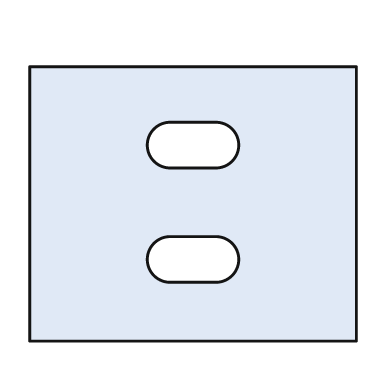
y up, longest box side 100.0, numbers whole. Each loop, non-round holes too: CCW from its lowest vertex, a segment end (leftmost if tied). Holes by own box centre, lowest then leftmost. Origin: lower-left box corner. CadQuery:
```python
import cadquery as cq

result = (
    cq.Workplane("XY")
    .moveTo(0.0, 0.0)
    .lineTo(100.0, 0.0)
    .lineTo(100.0, 84.0)
    .lineTo(0.0, 84.0)
    .close()
    .moveTo(43.0, 18.0)
    .lineTo(57.0, 18.0)
    .threePointArc((64.0, 25.0), (57.0, 32.0))
    .lineTo(43.0, 32.0)
    .threePointArc((36.0, 25.0), (43.0, 18.0))
    .close()
    .moveTo(43.0, 53.0)
    .lineTo(57.0, 53.0)
    .threePointArc((64.0, 60.0), (57.0, 67.0))
    .lineTo(43.0, 67.0)
    .threePointArc((36.0, 60.0), (43.0, 53.0))
    .close()
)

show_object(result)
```